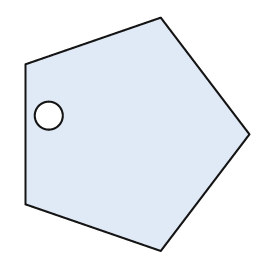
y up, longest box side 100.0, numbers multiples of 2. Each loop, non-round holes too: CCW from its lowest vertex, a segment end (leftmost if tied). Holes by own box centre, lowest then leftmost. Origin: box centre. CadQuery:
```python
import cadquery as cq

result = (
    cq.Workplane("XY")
    .moveTo(10.0, -50.0)
    .lineTo(48.0, 0.0)
    .lineTo(10.0, 50.0)
    .lineTo(-48.0, 30.0)
    .lineTo(-48.0, -30.0)
    .close()
    .moveTo(-38.0, 8.0)
    .circle(6.0)
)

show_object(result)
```